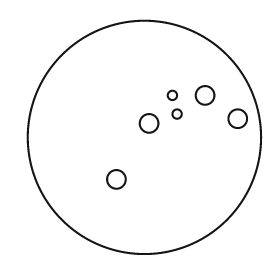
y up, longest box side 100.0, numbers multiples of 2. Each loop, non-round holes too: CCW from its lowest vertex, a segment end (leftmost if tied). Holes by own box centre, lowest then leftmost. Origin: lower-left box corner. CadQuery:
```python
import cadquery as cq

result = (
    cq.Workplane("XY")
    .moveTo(50.0, 50.0)
    .circle(50.0)
    .moveTo(38.0, 32.0)
    .circle(4.0)
    .moveTo(52.0, 56.0)
    .circle(4.0)
    .moveTo(90.0, 58.0)
    .circle(4.0)
    .moveTo(64.0, 60.0)
    .circle(2.0)
    .moveTo(62.0, 68.0)
    .circle(2.0)
    .moveTo(76.0, 68.0)
    .circle(4.0)
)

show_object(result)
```